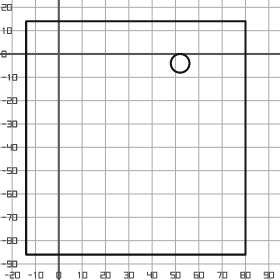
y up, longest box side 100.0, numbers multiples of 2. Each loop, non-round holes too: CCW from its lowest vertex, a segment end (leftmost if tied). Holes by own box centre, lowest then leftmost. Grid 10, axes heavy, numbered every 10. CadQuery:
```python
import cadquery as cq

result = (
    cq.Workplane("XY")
    .moveTo(-14.0, -86.0)
    .lineTo(80.0, -86.0)
    .lineTo(80.0, 14.0)
    .lineTo(-14.0, 14.0)
    .close()
    .moveTo(52.0, -4.0)
    .circle(4.0)
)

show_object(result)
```